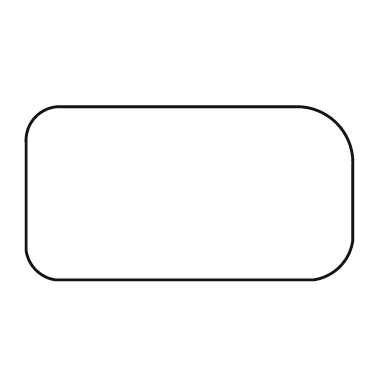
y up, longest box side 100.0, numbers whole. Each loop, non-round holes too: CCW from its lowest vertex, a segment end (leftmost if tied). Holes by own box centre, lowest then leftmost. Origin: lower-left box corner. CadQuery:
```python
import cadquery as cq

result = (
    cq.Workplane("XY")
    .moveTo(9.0, 0.0)
    .lineTo(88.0, 0.0)
    .threePointArc((96.0, 4.0), (100.0, 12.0))
    .lineTo(100.0, 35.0)
    .threePointArc((95.0, 48.0), (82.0, 53.0))
    .lineTo(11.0, 53.0)
    .threePointArc((3.0, 50.0), (0.0, 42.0))
    .lineTo(0.0, 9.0)
    .threePointArc((3.0, 3.0), (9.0, 0.0))
    .close()
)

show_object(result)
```